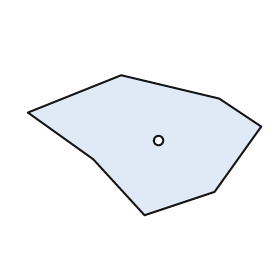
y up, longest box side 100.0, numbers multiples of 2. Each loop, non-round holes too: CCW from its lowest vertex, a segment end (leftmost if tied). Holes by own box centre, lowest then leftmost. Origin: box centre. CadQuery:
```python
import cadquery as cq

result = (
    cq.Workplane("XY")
    .moveTo(0.0, -30.0)
    .lineTo(30.0, -20.0)
    .lineTo(50.0, 8.0)
    .lineTo(32.0, 20.0)
    .lineTo(-10.0, 30.0)
    .lineTo(-50.0, 14.0)
    .lineTo(-22.0, -6.0)
    .close()
    .moveTo(6.0, 2.0)
    .circle(2.0)
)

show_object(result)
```